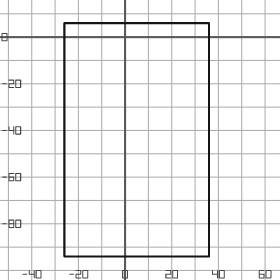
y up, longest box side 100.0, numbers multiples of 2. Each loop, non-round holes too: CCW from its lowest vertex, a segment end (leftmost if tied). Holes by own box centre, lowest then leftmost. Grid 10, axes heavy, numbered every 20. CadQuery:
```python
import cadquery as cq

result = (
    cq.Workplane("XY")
    .moveTo(-26.0, -94.0)
    .lineTo(36.0, -94.0)
    .lineTo(36.0, 6.0)
    .lineTo(-26.0, 6.0)
    .close()
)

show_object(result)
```